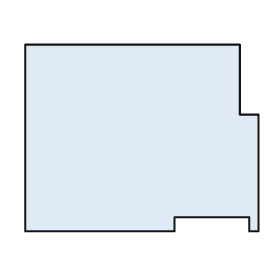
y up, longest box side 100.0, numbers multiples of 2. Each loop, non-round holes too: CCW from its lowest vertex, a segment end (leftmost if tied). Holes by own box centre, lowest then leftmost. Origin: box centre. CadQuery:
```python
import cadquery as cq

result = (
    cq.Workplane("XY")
    .moveTo(-50.0, -40.0)
    .lineTo(14.0, -40.0)
    .lineTo(14.0, -34.0)
    .lineTo(46.0, -34.0)
    .lineTo(46.0, -40.0)
    .lineTo(50.0, -40.0)
    .lineTo(50.0, 10.0)
    .lineTo(42.0, 10.0)
    .lineTo(42.0, 40.0)
    .lineTo(-50.0, 40.0)
    .close()
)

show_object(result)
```